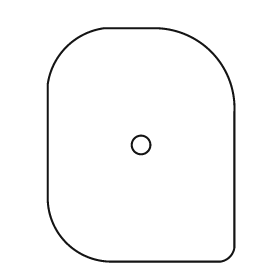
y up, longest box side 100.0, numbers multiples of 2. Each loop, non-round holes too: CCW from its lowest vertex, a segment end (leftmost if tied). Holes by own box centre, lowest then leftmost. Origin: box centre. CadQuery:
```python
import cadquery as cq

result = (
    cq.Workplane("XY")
    .moveTo(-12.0, -50.0)
    .lineTo(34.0, -50.0)
    .threePointArc((38.0, -48.0), (40.0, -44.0))
    .lineTo(40.0, 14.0)
    .threePointArc((30.0, 40.0), (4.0, 50.0))
    .lineTo(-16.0, 50.0)
    .threePointArc((-32.0, 42.0), (-40.0, 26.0))
    .lineTo(-40.0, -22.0)
    .threePointArc((-32.0, -42.0), (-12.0, -50.0))
    .close()
    .moveTo(0.0, 0.0)
    .circle(4.0)
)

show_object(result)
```